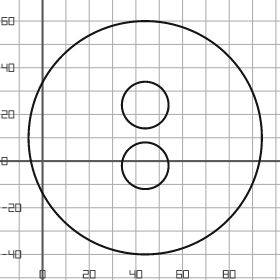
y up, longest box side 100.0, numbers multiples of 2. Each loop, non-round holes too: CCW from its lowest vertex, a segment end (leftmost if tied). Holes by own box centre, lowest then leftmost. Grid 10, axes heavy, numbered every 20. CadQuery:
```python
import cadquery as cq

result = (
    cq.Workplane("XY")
    .moveTo(44.0, 10.0)
    .circle(50.0)
    .moveTo(44.0, -2.0)
    .circle(10.0)
    .moveTo(44.0, 24.0)
    .circle(10.0)
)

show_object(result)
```